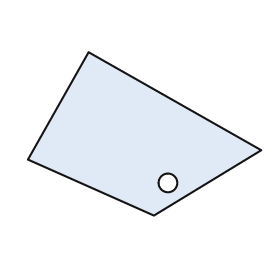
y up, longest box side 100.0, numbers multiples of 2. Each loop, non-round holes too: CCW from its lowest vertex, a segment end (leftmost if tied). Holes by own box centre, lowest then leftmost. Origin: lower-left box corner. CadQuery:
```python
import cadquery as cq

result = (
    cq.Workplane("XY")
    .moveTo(54.0, 0.0)
    .lineTo(100.0, 28.0)
    .lineTo(26.0, 70.0)
    .lineTo(0.0, 24.0)
    .close()
    .moveTo(60.0, 14.0)
    .circle(4.0)
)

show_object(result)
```